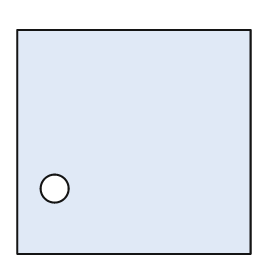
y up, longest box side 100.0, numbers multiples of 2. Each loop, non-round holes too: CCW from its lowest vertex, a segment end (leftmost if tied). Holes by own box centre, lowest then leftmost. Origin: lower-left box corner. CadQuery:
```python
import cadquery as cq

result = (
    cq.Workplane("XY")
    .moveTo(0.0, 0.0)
    .lineTo(100.0, 0.0)
    .lineTo(100.0, 96.0)
    .lineTo(0.0, 96.0)
    .close()
    .moveTo(16.0, 28.0)
    .circle(6.0)
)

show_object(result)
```